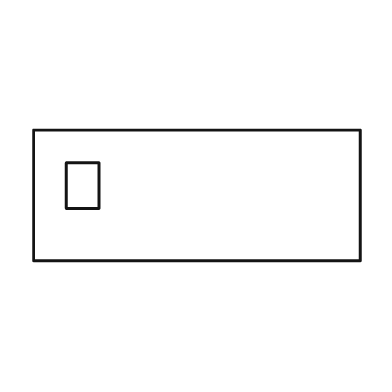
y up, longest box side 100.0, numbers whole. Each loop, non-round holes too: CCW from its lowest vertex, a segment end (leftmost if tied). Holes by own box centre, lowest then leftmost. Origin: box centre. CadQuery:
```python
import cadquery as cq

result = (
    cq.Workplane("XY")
    .moveTo(-50.0, -20.0)
    .lineTo(50.0, -20.0)
    .lineTo(50.0, 20.0)
    .lineTo(-50.0, 20.0)
    .close()
    .moveTo(-40.0, -4.0)
    .lineTo(-30.0, -4.0)
    .lineTo(-30.0, 10.0)
    .lineTo(-40.0, 10.0)
    .close()
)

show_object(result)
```